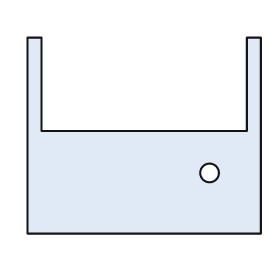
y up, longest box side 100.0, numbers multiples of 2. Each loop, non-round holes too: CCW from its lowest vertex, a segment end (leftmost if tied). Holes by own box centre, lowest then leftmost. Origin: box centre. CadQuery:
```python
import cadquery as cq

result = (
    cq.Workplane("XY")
    .moveTo(-50.0, -42.0)
    .lineTo(50.0, -42.0)
    .lineTo(50.0, 42.0)
    .lineTo(44.0, 42.0)
    .lineTo(44.0, 2.0)
    .lineTo(-44.0, 2.0)
    .lineTo(-44.0, 42.0)
    .lineTo(-50.0, 42.0)
    .close()
    .moveTo(28.0, -16.0)
    .circle(4.0)
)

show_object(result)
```